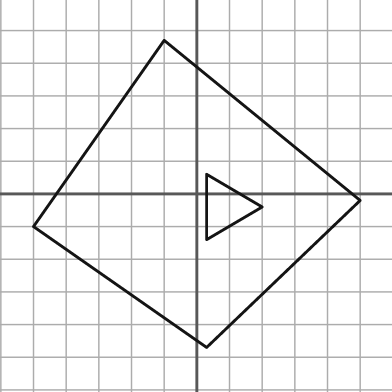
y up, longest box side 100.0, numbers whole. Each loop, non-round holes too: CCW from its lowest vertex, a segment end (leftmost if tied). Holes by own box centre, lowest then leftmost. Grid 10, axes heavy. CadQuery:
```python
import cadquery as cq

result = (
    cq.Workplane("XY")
    .moveTo(3.0, -47.0)
    .lineTo(50.0, -2.0)
    .lineTo(-10.0, 47.0)
    .lineTo(-50.0, -10.0)
    .close()
    .moveTo(3.0, -14.0)
    .lineTo(20.0, -4.0)
    .lineTo(3.0, 6.0)
    .close()
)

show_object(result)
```